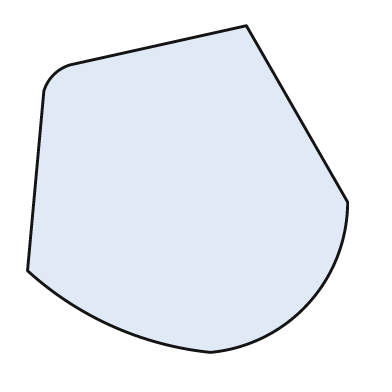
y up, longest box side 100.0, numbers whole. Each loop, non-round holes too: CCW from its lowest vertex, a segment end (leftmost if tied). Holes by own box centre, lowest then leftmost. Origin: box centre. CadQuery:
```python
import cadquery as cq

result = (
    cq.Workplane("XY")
    .moveTo(7.0, -50.0)
    .threePointArc((37.0, -35.0), (49.0, -4.0))
    .lineTo(18.0, 50.0)
    .lineTo(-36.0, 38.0)
    .threePointArc((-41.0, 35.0), (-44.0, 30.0))
    .lineTo(-49.0, -25.0)
    .threePointArc((-23.0, -42.0), (7.0, -50.0))
    .close()
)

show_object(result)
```